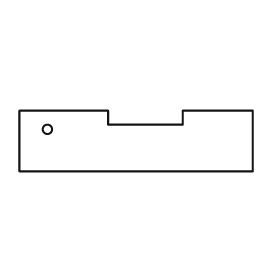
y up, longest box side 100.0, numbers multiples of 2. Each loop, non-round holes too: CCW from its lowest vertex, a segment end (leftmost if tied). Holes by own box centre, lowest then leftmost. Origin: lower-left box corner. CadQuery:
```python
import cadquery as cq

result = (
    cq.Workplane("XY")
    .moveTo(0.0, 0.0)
    .lineTo(100.0, 0.0)
    .lineTo(100.0, 26.0)
    .lineTo(70.0, 26.0)
    .lineTo(70.0, 20.0)
    .lineTo(38.0, 20.0)
    .lineTo(38.0, 26.0)
    .lineTo(0.0, 26.0)
    .close()
    .moveTo(12.0, 18.0)
    .circle(2.0)
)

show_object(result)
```